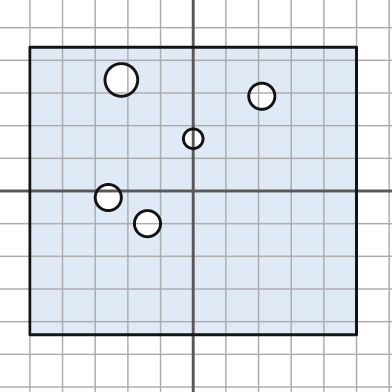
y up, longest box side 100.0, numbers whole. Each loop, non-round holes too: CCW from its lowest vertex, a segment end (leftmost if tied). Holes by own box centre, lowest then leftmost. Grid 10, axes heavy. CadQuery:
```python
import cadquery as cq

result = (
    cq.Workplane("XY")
    .moveTo(-50.0, -44.0)
    .lineTo(50.0, -44.0)
    .lineTo(50.0, 44.0)
    .lineTo(-50.0, 44.0)
    .close()
    .moveTo(-14.0, -10.0)
    .circle(4.0)
    .moveTo(-26.0, -2.0)
    .circle(4.0)
    .moveTo(0.0, 16.0)
    .circle(3.0)
    .moveTo(21.0, 29.0)
    .circle(4.0)
    .moveTo(-22.0, 34.0)
    .circle(5.0)
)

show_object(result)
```